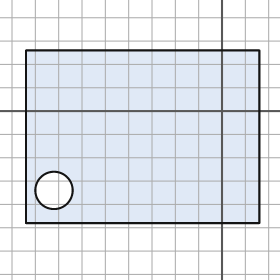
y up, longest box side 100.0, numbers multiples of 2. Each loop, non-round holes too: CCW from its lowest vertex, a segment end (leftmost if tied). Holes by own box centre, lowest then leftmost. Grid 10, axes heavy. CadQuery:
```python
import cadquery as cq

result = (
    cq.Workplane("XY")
    .moveTo(-84.0, -48.0)
    .lineTo(16.0, -48.0)
    .lineTo(16.0, 26.0)
    .lineTo(-84.0, 26.0)
    .close()
    .moveTo(-72.0, -34.0)
    .circle(8.0)
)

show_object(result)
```